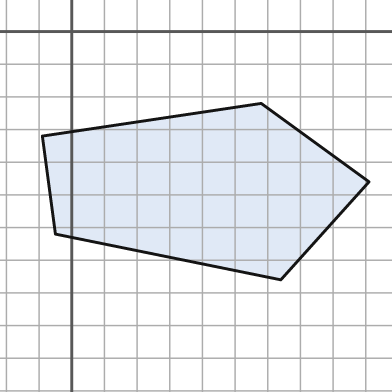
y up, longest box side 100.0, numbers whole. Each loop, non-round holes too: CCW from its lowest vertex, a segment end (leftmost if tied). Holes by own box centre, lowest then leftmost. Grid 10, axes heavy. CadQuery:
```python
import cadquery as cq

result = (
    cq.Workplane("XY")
    .moveTo(64.0, -76.0)
    .lineTo(91.0, -46.0)
    .lineTo(58.0, -22.0)
    .lineTo(-9.0, -32.0)
    .lineTo(-5.0, -62.0)
    .close()
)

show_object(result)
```